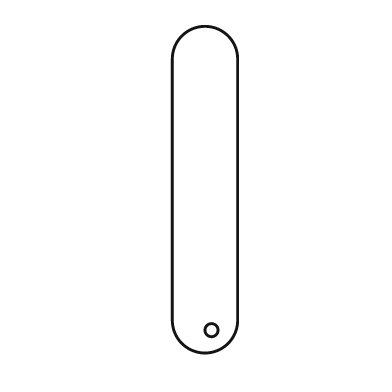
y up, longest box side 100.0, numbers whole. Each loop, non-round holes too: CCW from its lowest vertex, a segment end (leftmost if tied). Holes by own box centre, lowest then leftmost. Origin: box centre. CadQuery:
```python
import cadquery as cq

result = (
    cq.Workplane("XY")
    .moveTo(-10.0, -40.0)
    .threePointArc((0.0, -50.0), (10.0, -40.0))
    .lineTo(10.0, 40.0)
    .threePointArc((0.0, 50.0), (-10.0, 40.0))
    .close()
    .moveTo(2.0, -43.0)
    .circle(2.0)
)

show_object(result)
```